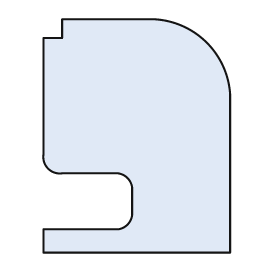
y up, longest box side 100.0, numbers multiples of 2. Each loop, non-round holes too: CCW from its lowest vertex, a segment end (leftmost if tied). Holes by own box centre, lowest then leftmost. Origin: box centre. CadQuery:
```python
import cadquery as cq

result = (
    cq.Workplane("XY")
    .moveTo(-40.0, -50.0)
    .lineTo(40.0, -50.0)
    .lineTo(40.0, 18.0)
    .threePointArc((30.0, 40.0), (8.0, 50.0))
    .lineTo(-32.0, 50.0)
    .lineTo(-32.0, 42.0)
    .lineTo(-40.0, 42.0)
    .lineTo(-40.0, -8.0)
    .threePointArc((-38.0, -14.0), (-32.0, -16.0))
    .lineTo(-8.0, -16.0)
    .threePointArc((-4.0, -18.0), (-2.0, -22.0))
    .lineTo(-2.0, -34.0)
    .threePointArc((-4.0, -38.0), (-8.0, -40.0))
    .lineTo(-40.0, -40.0)
    .close()
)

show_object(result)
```